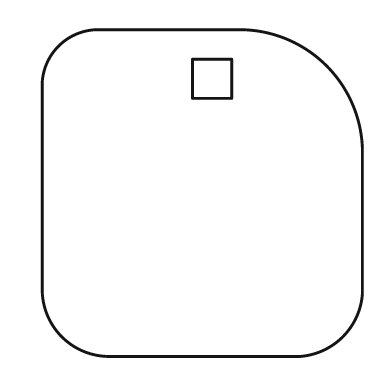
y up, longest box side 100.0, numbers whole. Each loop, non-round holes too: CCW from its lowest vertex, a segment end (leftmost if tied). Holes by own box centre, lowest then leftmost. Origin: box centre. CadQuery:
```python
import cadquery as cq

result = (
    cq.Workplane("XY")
    .moveTo(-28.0, -50.0)
    .lineTo(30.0, -50.0)
    .threePointArc((43.0, -44.0), (49.0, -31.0))
    .lineTo(49.0, 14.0)
    .threePointArc((38.0, 39.0), (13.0, 50.0))
    .lineTo(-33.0, 50.0)
    .threePointArc((-44.0, 45.0), (-49.0, 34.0))
    .lineTo(-49.0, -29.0)
    .threePointArc((-43.0, -44.0), (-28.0, -50.0))
    .close()
    .moveTo(-3.0, 29.0)
    .lineTo(9.0, 29.0)
    .lineTo(9.0, 41.0)
    .lineTo(-3.0, 41.0)
    .close()
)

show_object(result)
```